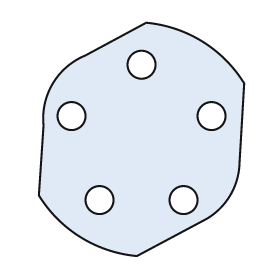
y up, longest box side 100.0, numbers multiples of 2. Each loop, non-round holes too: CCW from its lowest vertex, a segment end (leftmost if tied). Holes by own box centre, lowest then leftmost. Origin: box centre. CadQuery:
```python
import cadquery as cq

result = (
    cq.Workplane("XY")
    .moveTo(-2.0, -50.0)
    .lineTo(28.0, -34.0)
    .threePointArc((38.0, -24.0), (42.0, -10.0))
    .lineTo(44.0, 24.0)
    .threePointArc((26.0, 42.0), (2.0, 50.0))
    .lineTo(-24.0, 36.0)
    .threePointArc((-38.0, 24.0), (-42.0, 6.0))
    .lineTo(-44.0, -24.0)
    .threePointArc((-26.0, -42.0), (-2.0, -50.0))
    .close()
    .moveTo(-18.0, -26.0)
    .circle(6.0)
    .moveTo(18.0, -26.0)
    .circle(6.0)
    .moveTo(-30.0, 10.0)
    .circle(6.0)
    .moveTo(30.0, 10.0)
    .circle(6.0)
    .moveTo(0.0, 32.0)
    .circle(6.0)
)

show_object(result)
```